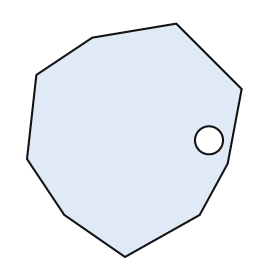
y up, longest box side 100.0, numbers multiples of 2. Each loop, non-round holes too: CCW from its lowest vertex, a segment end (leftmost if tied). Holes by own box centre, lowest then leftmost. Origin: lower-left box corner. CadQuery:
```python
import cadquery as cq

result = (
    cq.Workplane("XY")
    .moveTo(42.0, 0.0)
    .lineTo(74.0, 18.0)
    .lineTo(86.0, 40.0)
    .lineTo(92.0, 72.0)
    .lineTo(64.0, 100.0)
    .lineTo(28.0, 94.0)
    .lineTo(4.0, 78.0)
    .lineTo(0.0, 42.0)
    .lineTo(16.0, 18.0)
    .close()
    .moveTo(78.0, 50.0)
    .circle(6.0)
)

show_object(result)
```